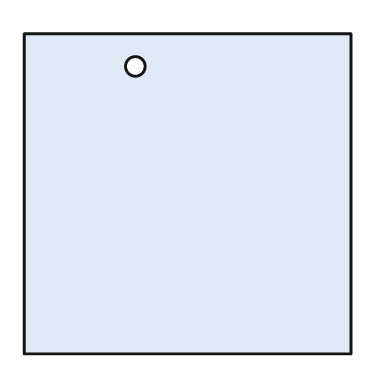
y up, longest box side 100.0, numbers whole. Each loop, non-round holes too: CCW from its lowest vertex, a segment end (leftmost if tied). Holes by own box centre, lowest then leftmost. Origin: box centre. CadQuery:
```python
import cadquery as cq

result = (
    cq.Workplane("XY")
    .moveTo(-50.0, -49.0)
    .lineTo(50.0, -49.0)
    .lineTo(50.0, 49.0)
    .lineTo(-50.0, 49.0)
    .close()
    .moveTo(-16.0, 39.0)
    .circle(3.0)
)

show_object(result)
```